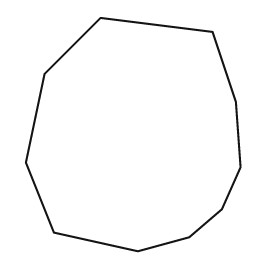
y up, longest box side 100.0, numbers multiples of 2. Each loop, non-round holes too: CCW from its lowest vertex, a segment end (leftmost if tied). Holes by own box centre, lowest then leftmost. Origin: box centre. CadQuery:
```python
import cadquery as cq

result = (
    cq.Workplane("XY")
    .moveTo(2.0, -50.0)
    .lineTo(24.0, -44.0)
    .lineTo(38.0, -32.0)
    .lineTo(46.0, -14.0)
    .lineTo(44.0, 14.0)
    .lineTo(34.0, 44.0)
    .lineTo(-14.0, 50.0)
    .lineTo(-38.0, 26.0)
    .lineTo(-46.0, -12.0)
    .lineTo(-34.0, -42.0)
    .close()
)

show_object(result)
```